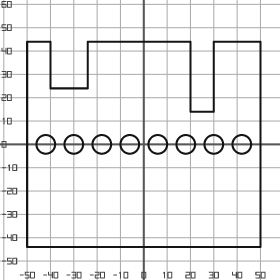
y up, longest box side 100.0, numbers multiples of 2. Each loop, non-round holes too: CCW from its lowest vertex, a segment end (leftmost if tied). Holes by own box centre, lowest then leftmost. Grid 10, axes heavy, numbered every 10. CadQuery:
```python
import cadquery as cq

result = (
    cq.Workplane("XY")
    .moveTo(-50.0, -44.0)
    .lineTo(50.0, -44.0)
    .lineTo(50.0, 44.0)
    .lineTo(30.0, 44.0)
    .lineTo(30.0, 14.0)
    .lineTo(20.0, 14.0)
    .lineTo(20.0, 44.0)
    .lineTo(-24.0, 44.0)
    .lineTo(-24.0, 24.0)
    .lineTo(-40.0, 24.0)
    .lineTo(-40.0, 44.0)
    .lineTo(-50.0, 44.0)
    .close()
    .moveTo(-42.0, 0.0)
    .circle(4.0)
    .moveTo(-30.0, 0.0)
    .circle(4.0)
    .moveTo(-18.0, 0.0)
    .circle(4.0)
    .moveTo(-6.0, 0.0)
    .circle(4.0)
    .moveTo(6.0, 0.0)
    .circle(4.0)
    .moveTo(18.0, 0.0)
    .circle(4.0)
    .moveTo(30.0, 0.0)
    .circle(4.0)
    .moveTo(42.0, 0.0)
    .circle(4.0)
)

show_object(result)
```